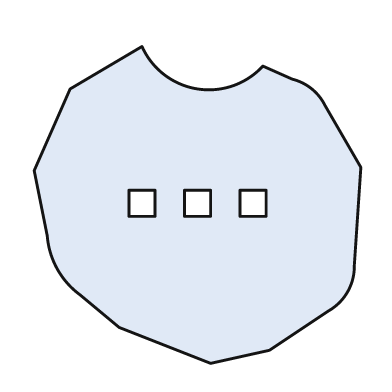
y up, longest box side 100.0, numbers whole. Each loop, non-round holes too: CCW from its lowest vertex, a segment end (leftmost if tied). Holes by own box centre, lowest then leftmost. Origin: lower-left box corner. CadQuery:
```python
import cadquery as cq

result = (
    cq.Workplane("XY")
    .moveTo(54.0, 0.0)
    .lineTo(72.0, 4.0)
    .lineTo(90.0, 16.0)
    .threePointArc((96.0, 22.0), (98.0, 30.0))
    .lineTo(100.0, 60.0)
    .lineTo(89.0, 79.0)
    .threePointArc((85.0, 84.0), (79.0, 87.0))
    .lineTo(70.0, 91.0)
    .threePointArc((50.0, 84.0), (33.0, 97.0))
    .lineTo(11.0, 84.0)
    .lineTo(0.0, 59.0)
    .lineTo(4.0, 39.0)
    .threePointArc((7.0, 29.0), (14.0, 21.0))
    .lineTo(26.0, 11.0)
    .close()
    .moveTo(29.0, 45.0)
    .lineTo(37.0, 45.0)
    .lineTo(37.0, 53.0)
    .lineTo(29.0, 53.0)
    .close()
    .moveTo(46.0, 45.0)
    .lineTo(54.0, 45.0)
    .lineTo(54.0, 53.0)
    .lineTo(46.0, 53.0)
    .close()
    .moveTo(63.0, 45.0)
    .lineTo(71.0, 45.0)
    .lineTo(71.0, 53.0)
    .lineTo(63.0, 53.0)
    .close()
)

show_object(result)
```